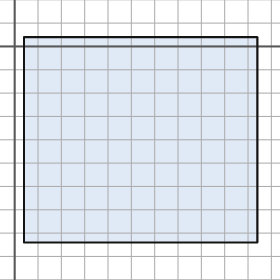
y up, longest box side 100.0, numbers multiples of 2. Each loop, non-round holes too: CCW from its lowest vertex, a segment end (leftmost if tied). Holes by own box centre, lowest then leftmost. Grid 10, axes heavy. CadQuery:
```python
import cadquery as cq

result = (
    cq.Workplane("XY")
    .moveTo(4.0, -84.0)
    .lineTo(104.0, -84.0)
    .lineTo(104.0, 4.0)
    .lineTo(4.0, 4.0)
    .close()
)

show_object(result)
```